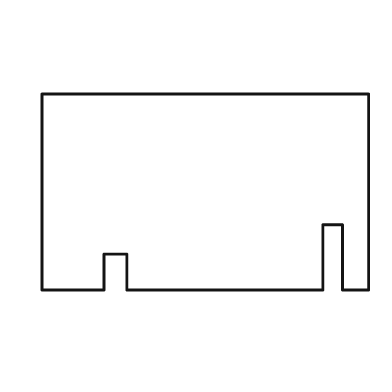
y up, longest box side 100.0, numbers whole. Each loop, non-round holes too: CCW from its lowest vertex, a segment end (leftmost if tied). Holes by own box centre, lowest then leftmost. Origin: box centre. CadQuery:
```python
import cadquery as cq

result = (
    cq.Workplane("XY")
    .moveTo(-50.0, -30.0)
    .lineTo(-31.0, -30.0)
    .lineTo(-31.0, -19.0)
    .lineTo(-24.0, -19.0)
    .lineTo(-24.0, -30.0)
    .lineTo(36.0, -30.0)
    .lineTo(36.0, -10.0)
    .lineTo(42.0, -10.0)
    .lineTo(42.0, -30.0)
    .lineTo(50.0, -30.0)
    .lineTo(50.0, 30.0)
    .lineTo(-50.0, 30.0)
    .close()
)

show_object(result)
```